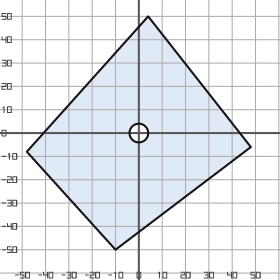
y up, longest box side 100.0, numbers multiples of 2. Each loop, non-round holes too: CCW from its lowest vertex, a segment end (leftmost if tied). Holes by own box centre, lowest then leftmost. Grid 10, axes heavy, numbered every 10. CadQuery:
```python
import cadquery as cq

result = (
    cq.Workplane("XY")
    .moveTo(-10.0, -50.0)
    .lineTo(48.0, -6.0)
    .lineTo(4.0, 50.0)
    .lineTo(-48.0, -8.0)
    .close()
    .moveTo(0.0, 0.0)
    .circle(4.0)
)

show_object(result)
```